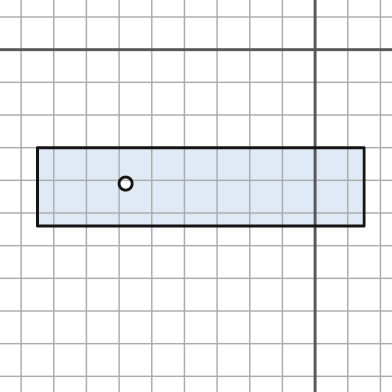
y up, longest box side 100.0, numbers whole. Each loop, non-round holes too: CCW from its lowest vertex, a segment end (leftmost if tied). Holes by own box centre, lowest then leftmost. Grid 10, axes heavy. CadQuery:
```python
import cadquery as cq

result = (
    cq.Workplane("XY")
    .moveTo(-85.0, -54.0)
    .lineTo(15.0, -54.0)
    .lineTo(15.0, -30.0)
    .lineTo(-85.0, -30.0)
    .close()
    .moveTo(-58.0, -41.0)
    .circle(2.0)
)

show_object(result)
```